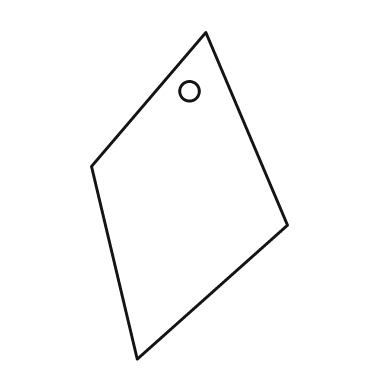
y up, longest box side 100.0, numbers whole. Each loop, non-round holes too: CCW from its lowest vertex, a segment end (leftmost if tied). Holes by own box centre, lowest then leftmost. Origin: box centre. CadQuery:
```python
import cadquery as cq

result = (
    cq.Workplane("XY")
    .moveTo(-16.0, -50.0)
    .lineTo(30.0, -9.0)
    .lineTo(5.0, 50.0)
    .lineTo(-30.0, 9.0)
    .close()
    .moveTo(0.0, 32.0)
    .circle(3.0)
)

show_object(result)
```